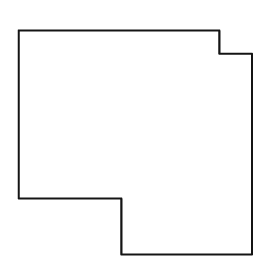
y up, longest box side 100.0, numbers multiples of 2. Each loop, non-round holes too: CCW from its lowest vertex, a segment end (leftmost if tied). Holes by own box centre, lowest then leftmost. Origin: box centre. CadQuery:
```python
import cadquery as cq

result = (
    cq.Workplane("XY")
    .moveTo(-6.0, -48.0)
    .lineTo(50.0, -48.0)
    .lineTo(50.0, 38.0)
    .lineTo(36.0, 38.0)
    .lineTo(36.0, 48.0)
    .lineTo(-50.0, 48.0)
    .lineTo(-50.0, -24.0)
    .lineTo(-6.0, -24.0)
    .close()
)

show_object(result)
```